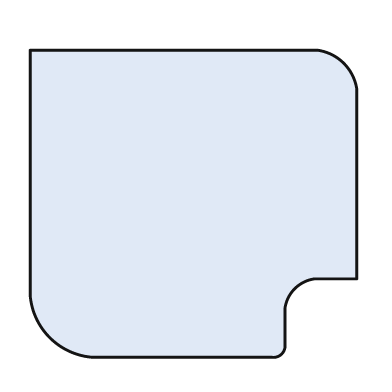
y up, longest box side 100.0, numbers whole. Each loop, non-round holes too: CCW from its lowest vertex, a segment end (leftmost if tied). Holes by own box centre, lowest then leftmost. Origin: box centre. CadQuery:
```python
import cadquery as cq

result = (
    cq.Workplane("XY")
    .moveTo(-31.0, -47.0)
    .lineTo(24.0, -47.0)
    .threePointArc((27.0, -46.0), (28.0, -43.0))
    .lineTo(28.0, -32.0)
    .threePointArc((31.0, -26.0), (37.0, -23.0))
    .lineTo(50.0, -23.0)
    .lineTo(50.0, 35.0)
    .threePointArc((46.0, 43.0), (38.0, 47.0))
    .lineTo(-50.0, 47.0)
    .lineTo(-50.0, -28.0)
    .threePointArc((-44.0, -41.0), (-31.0, -47.0))
    .close()
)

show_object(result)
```